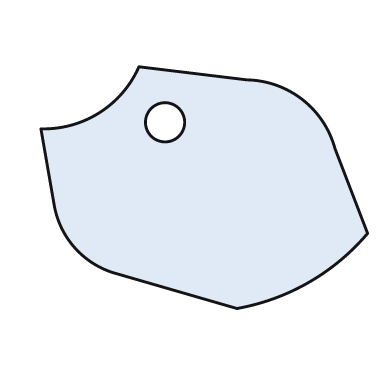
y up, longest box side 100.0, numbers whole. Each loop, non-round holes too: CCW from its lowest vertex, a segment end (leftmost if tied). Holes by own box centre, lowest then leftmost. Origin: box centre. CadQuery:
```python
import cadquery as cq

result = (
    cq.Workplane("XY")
    .moveTo(10.0, -37.0)
    .threePointArc((32.0, -29.0), (50.0, -14.0))
    .lineTo(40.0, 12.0)
    .threePointArc((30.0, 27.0), (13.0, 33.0))
    .lineTo(-20.0, 37.0)
    .threePointArc((-32.0, 23.0), (-50.0, 18.0))
    .lineTo(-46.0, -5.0)
    .threePointArc((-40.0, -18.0), (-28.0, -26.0))
    .close()
    .moveTo(-12.0, 20.0)
    .circle(6.0)
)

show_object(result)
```